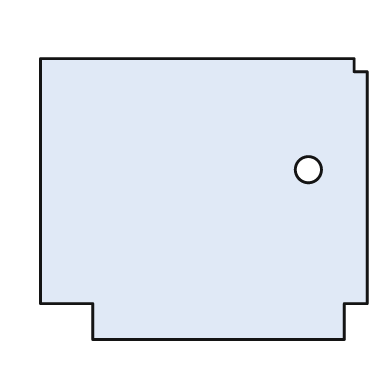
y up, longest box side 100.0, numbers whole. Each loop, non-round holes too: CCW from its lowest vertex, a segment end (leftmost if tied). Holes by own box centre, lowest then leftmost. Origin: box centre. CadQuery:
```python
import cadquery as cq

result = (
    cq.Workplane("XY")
    .moveTo(-34.0, -43.0)
    .lineTo(43.0, -43.0)
    .lineTo(43.0, -32.0)
    .lineTo(50.0, -32.0)
    .lineTo(50.0, 39.0)
    .lineTo(46.0, 39.0)
    .lineTo(46.0, 43.0)
    .lineTo(-50.0, 43.0)
    .lineTo(-50.0, -32.0)
    .lineTo(-34.0, -32.0)
    .close()
    .moveTo(32.0, 9.0)
    .circle(4.0)
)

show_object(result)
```